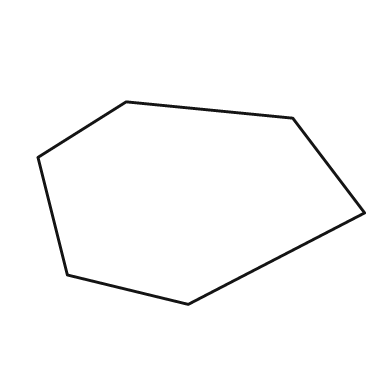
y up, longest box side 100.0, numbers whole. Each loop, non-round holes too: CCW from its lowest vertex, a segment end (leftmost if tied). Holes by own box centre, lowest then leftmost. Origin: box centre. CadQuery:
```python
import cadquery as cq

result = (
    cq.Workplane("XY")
    .moveTo(-4.0, -31.0)
    .lineTo(50.0, -3.0)
    .lineTo(28.0, 26.0)
    .lineTo(-23.0, 31.0)
    .lineTo(-50.0, 14.0)
    .lineTo(-41.0, -22.0)
    .close()
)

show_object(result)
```